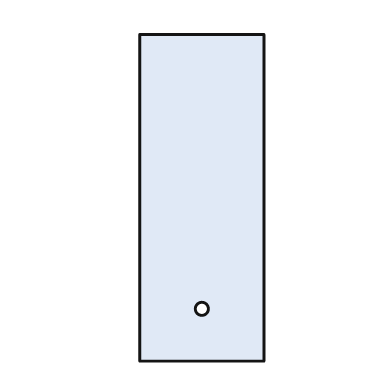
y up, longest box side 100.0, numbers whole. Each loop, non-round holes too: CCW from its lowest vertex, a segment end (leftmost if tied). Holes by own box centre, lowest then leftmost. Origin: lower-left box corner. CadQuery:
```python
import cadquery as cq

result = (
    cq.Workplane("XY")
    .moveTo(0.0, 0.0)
    .lineTo(38.0, 0.0)
    .lineTo(38.0, 100.0)
    .lineTo(0.0, 100.0)
    .close()
    .moveTo(19.0, 16.0)
    .circle(2.0)
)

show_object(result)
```